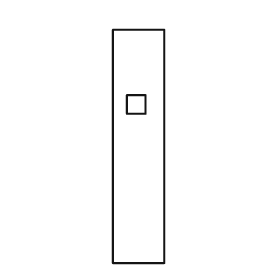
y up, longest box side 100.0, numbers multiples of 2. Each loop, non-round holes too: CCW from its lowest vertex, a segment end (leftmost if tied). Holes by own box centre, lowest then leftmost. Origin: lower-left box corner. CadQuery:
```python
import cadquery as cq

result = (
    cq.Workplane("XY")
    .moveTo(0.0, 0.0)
    .lineTo(22.0, 0.0)
    .lineTo(22.0, 100.0)
    .lineTo(0.0, 100.0)
    .close()
    .moveTo(6.0, 64.0)
    .lineTo(14.0, 64.0)
    .lineTo(14.0, 72.0)
    .lineTo(6.0, 72.0)
    .close()
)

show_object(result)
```